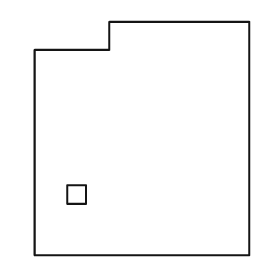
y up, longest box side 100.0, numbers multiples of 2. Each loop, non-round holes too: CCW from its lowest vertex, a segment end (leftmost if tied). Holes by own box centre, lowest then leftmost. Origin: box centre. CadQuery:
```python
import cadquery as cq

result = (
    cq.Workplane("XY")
    .moveTo(-46.0, -50.0)
    .lineTo(46.0, -50.0)
    .lineTo(46.0, 50.0)
    .lineTo(-14.0, 50.0)
    .lineTo(-14.0, 38.0)
    .lineTo(-46.0, 38.0)
    .close()
    .moveTo(-32.0, -28.0)
    .lineTo(-24.0, -28.0)
    .lineTo(-24.0, -20.0)
    .lineTo(-32.0, -20.0)
    .close()
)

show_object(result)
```